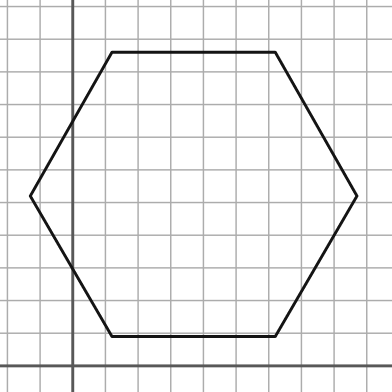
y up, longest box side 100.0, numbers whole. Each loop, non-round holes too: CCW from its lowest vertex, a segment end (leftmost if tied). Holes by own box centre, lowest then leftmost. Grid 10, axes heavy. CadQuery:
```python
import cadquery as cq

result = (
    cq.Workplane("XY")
    .moveTo(12.0, 9.0)
    .lineTo(62.0, 9.0)
    .lineTo(87.0, 52.0)
    .lineTo(62.0, 96.0)
    .lineTo(12.0, 96.0)
    .lineTo(-13.0, 52.0)
    .close()
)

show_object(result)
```